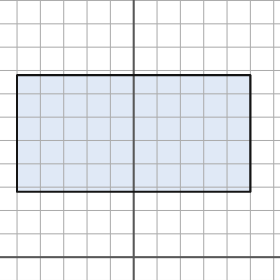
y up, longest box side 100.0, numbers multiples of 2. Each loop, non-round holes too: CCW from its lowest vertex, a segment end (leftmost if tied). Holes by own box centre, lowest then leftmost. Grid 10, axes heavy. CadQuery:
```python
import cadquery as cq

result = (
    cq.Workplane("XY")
    .moveTo(-50.0, 28.0)
    .lineTo(50.0, 28.0)
    .lineTo(50.0, 78.0)
    .lineTo(-50.0, 78.0)
    .close()
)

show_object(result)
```